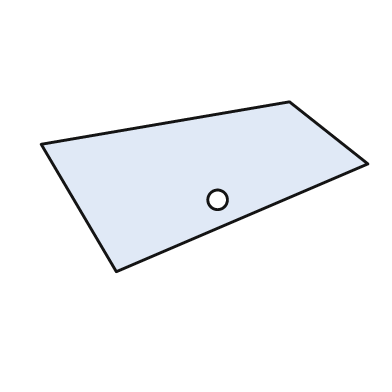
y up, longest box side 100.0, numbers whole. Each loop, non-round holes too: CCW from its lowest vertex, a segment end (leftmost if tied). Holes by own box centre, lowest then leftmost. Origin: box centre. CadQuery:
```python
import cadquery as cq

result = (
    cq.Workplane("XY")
    .moveTo(-27.0, -26.0)
    .lineTo(50.0, 7.0)
    .lineTo(26.0, 26.0)
    .lineTo(-50.0, 13.0)
    .close()
    .moveTo(4.0, -4.0)
    .circle(3.0)
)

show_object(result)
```